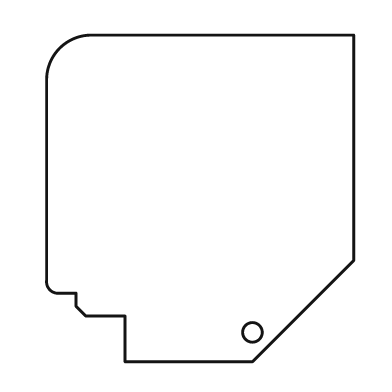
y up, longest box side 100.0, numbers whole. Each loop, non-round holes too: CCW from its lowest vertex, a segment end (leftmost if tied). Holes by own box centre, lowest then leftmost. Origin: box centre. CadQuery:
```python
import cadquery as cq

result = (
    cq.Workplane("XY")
    .moveTo(-23.0, -50.0)
    .lineTo(16.0, -50.0)
    .lineTo(47.0, -19.0)
    .lineTo(47.0, 50.0)
    .lineTo(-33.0, 50.0)
    .threePointArc((-43.0, 46.0), (-47.0, 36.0))
    .lineTo(-47.0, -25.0)
    .threePointArc((-46.0, -28.0), (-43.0, -29.0))
    .lineTo(-38.0, -29.0)
    .lineTo(-38.0, -33.0)
    .lineTo(-35.0, -36.0)
    .lineTo(-23.0, -36.0)
    .close()
    .moveTo(16.0, -41.0)
    .circle(3.0)
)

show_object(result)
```